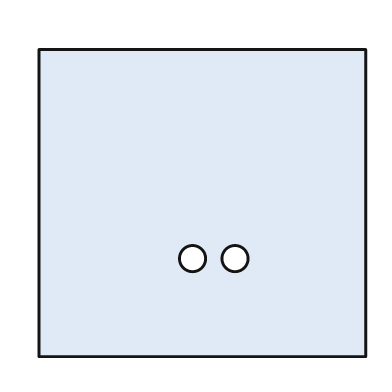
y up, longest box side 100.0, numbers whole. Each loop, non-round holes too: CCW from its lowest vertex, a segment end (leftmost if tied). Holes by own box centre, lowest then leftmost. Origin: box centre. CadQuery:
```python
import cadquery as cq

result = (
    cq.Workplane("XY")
    .moveTo(-50.0, -47.0)
    .lineTo(50.0, -47.0)
    .lineTo(50.0, 47.0)
    .lineTo(-50.0, 47.0)
    .close()
    .moveTo(-3.0, -17.0)
    .circle(4.0)
    .moveTo(10.0, -17.0)
    .circle(4.0)
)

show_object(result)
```